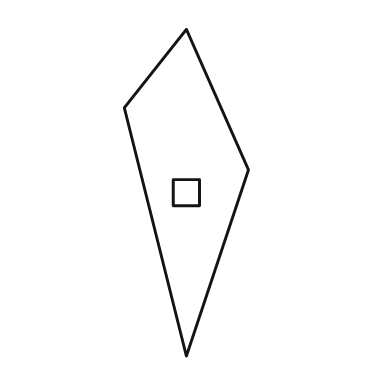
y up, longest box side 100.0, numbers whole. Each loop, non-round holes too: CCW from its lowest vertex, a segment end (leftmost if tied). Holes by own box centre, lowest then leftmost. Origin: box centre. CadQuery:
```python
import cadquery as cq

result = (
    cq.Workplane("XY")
    .moveTo(0.0, -50.0)
    .lineTo(19.0, 7.0)
    .lineTo(0.0, 50.0)
    .lineTo(-19.0, 26.0)
    .close()
    .moveTo(-4.0, -4.0)
    .lineTo(4.0, -4.0)
    .lineTo(4.0, 4.0)
    .lineTo(-4.0, 4.0)
    .close()
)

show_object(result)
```